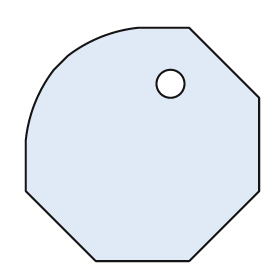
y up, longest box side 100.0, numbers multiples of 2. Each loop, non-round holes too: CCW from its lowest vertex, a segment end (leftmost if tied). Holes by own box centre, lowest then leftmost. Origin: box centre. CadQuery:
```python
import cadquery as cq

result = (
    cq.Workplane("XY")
    .moveTo(-20.0, -50.0)
    .lineTo(20.0, -50.0)
    .lineTo(50.0, -20.0)
    .lineTo(50.0, 20.0)
    .lineTo(20.0, 50.0)
    .lineTo(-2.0, 50.0)
    .threePointArc((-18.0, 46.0), (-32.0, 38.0))
    .lineTo(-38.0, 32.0)
    .threePointArc((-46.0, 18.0), (-50.0, 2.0))
    .lineTo(-50.0, -20.0)
    .close()
    .moveTo(12.0, 26.0)
    .circle(6.0)
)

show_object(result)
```